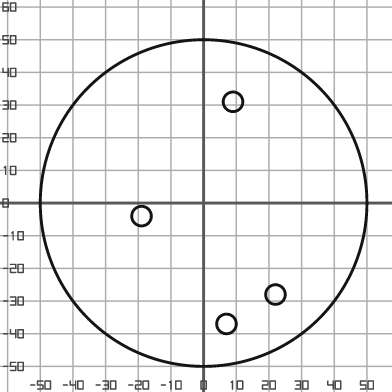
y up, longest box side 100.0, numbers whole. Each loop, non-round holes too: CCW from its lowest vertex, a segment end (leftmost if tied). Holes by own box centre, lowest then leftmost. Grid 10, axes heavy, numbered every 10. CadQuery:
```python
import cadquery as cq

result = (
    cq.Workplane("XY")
    .moveTo(0.0, 0.0)
    .circle(50.0)
    .moveTo(7.0, -37.0)
    .circle(3.0)
    .moveTo(22.0, -28.0)
    .circle(3.0)
    .moveTo(-19.0, -4.0)
    .circle(3.0)
    .moveTo(9.0, 31.0)
    .circle(3.0)
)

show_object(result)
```